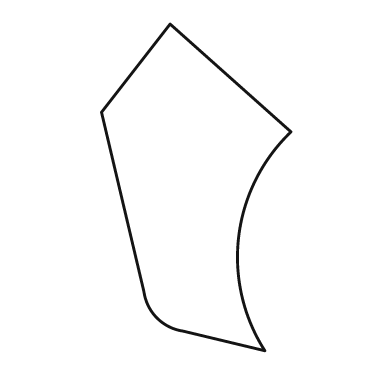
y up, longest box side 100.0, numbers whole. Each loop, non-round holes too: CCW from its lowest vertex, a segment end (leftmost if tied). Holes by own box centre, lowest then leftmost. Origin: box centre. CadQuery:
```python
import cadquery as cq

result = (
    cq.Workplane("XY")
    .moveTo(21.0, -50.0)
    .threePointArc((13.0, -15.0), (29.0, 17.0))
    .lineTo(-8.0, 50.0)
    .lineTo(-29.0, 23.0)
    .lineTo(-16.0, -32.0)
    .threePointArc((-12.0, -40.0), (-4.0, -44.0))
    .close()
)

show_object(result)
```